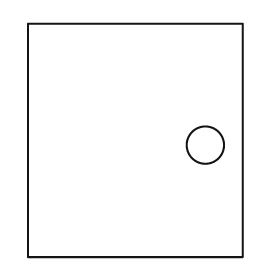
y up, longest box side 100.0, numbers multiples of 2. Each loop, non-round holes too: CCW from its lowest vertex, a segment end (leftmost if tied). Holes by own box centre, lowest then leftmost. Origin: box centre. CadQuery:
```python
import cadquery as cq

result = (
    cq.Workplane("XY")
    .moveTo(-46.0, -50.0)
    .lineTo(46.0, -50.0)
    .lineTo(46.0, 50.0)
    .lineTo(-46.0, 50.0)
    .close()
    .moveTo(30.0, -2.0)
    .circle(8.0)
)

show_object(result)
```